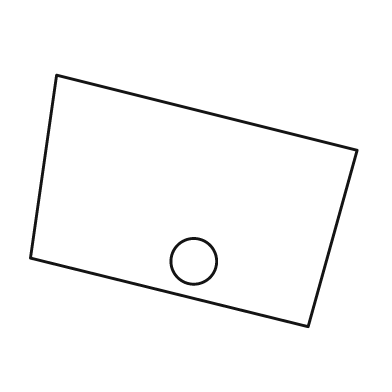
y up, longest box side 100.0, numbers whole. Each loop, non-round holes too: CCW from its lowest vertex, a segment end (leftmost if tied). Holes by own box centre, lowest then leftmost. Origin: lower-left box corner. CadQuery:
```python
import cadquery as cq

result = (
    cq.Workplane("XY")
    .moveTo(85.0, 0.0)
    .lineTo(100.0, 54.0)
    .lineTo(8.0, 77.0)
    .lineTo(0.0, 21.0)
    .close()
    .moveTo(50.0, 20.0)
    .circle(7.0)
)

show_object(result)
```